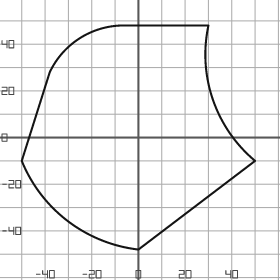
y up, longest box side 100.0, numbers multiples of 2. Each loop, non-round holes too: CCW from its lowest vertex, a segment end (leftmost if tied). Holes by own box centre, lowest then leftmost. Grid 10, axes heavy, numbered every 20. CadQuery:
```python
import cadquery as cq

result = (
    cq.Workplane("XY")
    .moveTo(0.0, -48.0)
    .lineTo(50.0, -10.0)
    .threePointArc((32.0, 16.0), (30.0, 48.0))
    .lineTo(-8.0, 48.0)
    .threePointArc((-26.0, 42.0), (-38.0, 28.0))
    .lineTo(-50.0, -10.0)
    .threePointArc((-30.0, -36.0), (0.0, -48.0))
    .close()
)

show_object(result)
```